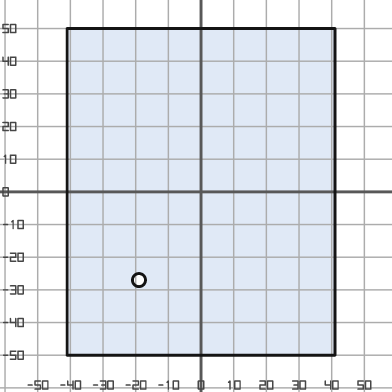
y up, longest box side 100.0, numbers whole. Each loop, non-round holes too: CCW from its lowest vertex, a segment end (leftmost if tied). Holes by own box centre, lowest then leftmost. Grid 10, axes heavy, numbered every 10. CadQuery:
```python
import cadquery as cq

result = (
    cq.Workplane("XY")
    .moveTo(-41.0, -50.0)
    .lineTo(41.0, -50.0)
    .lineTo(41.0, 50.0)
    .lineTo(-41.0, 50.0)
    .close()
    .moveTo(-19.0, -27.0)
    .circle(2.0)
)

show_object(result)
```